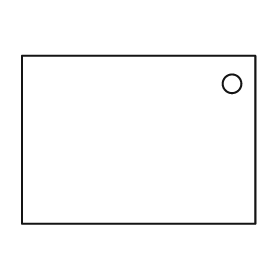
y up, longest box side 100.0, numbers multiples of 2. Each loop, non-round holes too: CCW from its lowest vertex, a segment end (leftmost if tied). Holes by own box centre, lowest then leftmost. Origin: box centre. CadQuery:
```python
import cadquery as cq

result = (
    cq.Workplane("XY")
    .moveTo(-50.0, -36.0)
    .lineTo(50.0, -36.0)
    .lineTo(50.0, 36.0)
    .lineTo(-50.0, 36.0)
    .close()
    .moveTo(40.0, 24.0)
    .circle(4.0)
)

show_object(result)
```